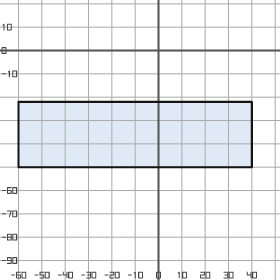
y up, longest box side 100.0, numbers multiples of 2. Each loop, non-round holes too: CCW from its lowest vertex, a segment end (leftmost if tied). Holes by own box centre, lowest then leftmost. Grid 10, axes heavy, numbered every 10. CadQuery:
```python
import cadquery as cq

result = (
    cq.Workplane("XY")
    .moveTo(-60.0, -50.0)
    .lineTo(40.0, -50.0)
    .lineTo(40.0, -22.0)
    .lineTo(-60.0, -22.0)
    .close()
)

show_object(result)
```